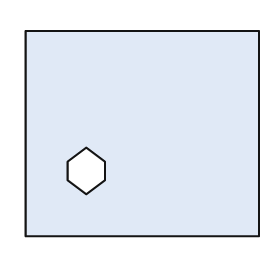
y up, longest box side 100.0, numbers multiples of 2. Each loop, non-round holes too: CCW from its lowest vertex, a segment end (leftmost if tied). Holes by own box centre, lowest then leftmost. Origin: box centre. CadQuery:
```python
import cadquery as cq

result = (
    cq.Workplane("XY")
    .moveTo(-50.0, -44.0)
    .lineTo(50.0, -44.0)
    .lineTo(50.0, 44.0)
    .lineTo(-50.0, 44.0)
    .close()
    .moveTo(-24.0, -26.0)
    .lineTo(-16.0, -20.0)
    .lineTo(-16.0, -12.0)
    .lineTo(-24.0, -6.0)
    .lineTo(-32.0, -12.0)
    .lineTo(-32.0, -20.0)
    .close()
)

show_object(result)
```